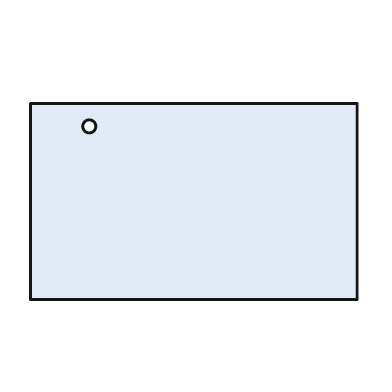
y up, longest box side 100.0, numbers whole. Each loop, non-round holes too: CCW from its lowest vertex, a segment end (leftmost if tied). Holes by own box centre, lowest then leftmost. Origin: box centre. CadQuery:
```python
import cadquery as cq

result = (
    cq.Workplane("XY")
    .moveTo(-50.0, -30.0)
    .lineTo(50.0, -30.0)
    .lineTo(50.0, 30.0)
    .lineTo(-50.0, 30.0)
    .close()
    .moveTo(-32.0, 23.0)
    .circle(2.0)
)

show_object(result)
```